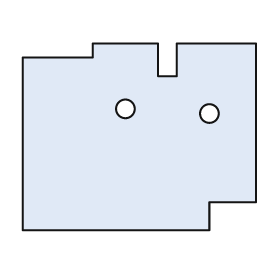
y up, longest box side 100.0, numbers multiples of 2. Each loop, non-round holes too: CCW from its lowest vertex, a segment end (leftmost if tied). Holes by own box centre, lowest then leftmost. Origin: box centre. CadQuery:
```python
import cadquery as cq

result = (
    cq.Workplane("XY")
    .moveTo(-50.0, -40.0)
    .lineTo(30.0, -40.0)
    .lineTo(30.0, -28.0)
    .lineTo(50.0, -28.0)
    .lineTo(50.0, 40.0)
    .lineTo(16.0, 40.0)
    .lineTo(16.0, 26.0)
    .lineTo(8.0, 26.0)
    .lineTo(8.0, 40.0)
    .lineTo(-20.0, 40.0)
    .lineTo(-20.0, 34.0)
    .lineTo(-50.0, 34.0)
    .close()
    .moveTo(30.0, 10.0)
    .circle(4.0)
    .moveTo(-6.0, 12.0)
    .circle(4.0)
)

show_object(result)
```